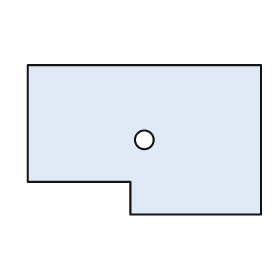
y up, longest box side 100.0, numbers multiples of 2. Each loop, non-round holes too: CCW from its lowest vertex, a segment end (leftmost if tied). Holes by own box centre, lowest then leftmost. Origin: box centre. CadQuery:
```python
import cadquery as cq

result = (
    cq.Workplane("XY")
    .moveTo(-6.0, -32.0)
    .lineTo(50.0, -32.0)
    .lineTo(50.0, 32.0)
    .lineTo(-50.0, 32.0)
    .lineTo(-50.0, -18.0)
    .lineTo(-6.0, -18.0)
    .close()
    .moveTo(0.0, 0.0)
    .circle(4.0)
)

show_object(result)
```